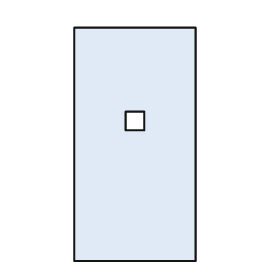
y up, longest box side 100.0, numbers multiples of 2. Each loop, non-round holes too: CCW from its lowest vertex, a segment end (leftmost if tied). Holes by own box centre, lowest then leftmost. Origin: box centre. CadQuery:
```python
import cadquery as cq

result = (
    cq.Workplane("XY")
    .moveTo(-26.0, -50.0)
    .lineTo(26.0, -50.0)
    .lineTo(26.0, 50.0)
    .lineTo(-26.0, 50.0)
    .close()
    .moveTo(-4.0, 6.0)
    .lineTo(4.0, 6.0)
    .lineTo(4.0, 14.0)
    .lineTo(-4.0, 14.0)
    .close()
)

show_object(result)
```